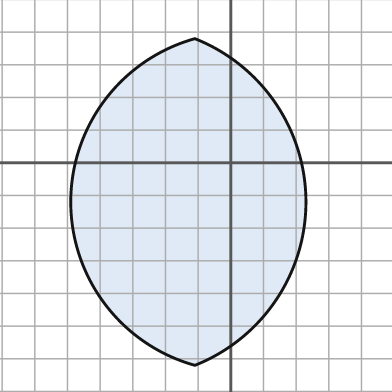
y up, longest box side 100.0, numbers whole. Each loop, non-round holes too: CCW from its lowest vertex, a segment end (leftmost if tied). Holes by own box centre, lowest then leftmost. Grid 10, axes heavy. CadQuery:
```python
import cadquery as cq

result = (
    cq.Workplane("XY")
    .moveTo(-11.0, -62.0)
    .threePointArc((23.0, -12.0), (-11.0, 38.0))
    .threePointArc((-49.0, -12.0), (-11.0, -62.0))
    .close()
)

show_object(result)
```